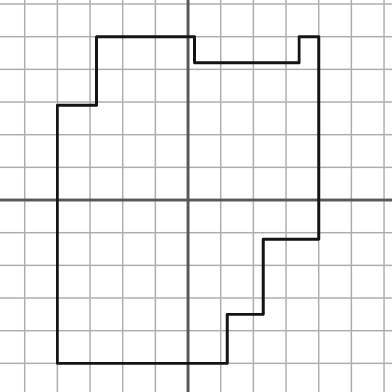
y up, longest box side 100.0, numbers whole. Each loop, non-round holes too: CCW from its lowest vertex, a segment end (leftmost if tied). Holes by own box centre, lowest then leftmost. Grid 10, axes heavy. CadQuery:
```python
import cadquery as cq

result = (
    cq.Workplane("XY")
    .moveTo(-40.0, -50.0)
    .lineTo(12.0, -50.0)
    .lineTo(12.0, -35.0)
    .lineTo(23.0, -35.0)
    .lineTo(23.0, -12.0)
    .lineTo(40.0, -12.0)
    .lineTo(40.0, 50.0)
    .lineTo(34.0, 50.0)
    .lineTo(34.0, 42.0)
    .lineTo(2.0, 42.0)
    .lineTo(2.0, 50.0)
    .lineTo(-28.0, 50.0)
    .lineTo(-28.0, 29.0)
    .lineTo(-40.0, 29.0)
    .close()
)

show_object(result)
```